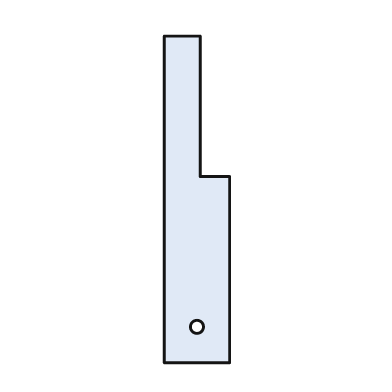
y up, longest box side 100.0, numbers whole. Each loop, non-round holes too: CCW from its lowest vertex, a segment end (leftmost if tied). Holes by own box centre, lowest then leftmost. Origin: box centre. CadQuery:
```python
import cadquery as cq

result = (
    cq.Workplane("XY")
    .moveTo(-10.0, -50.0)
    .lineTo(10.0, -50.0)
    .lineTo(10.0, 7.0)
    .lineTo(1.0, 7.0)
    .lineTo(1.0, 50.0)
    .lineTo(-10.0, 50.0)
    .close()
    .moveTo(0.0, -39.0)
    .circle(2.0)
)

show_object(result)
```